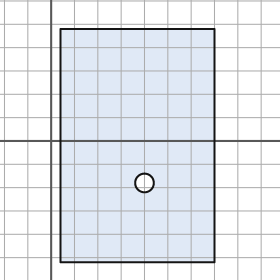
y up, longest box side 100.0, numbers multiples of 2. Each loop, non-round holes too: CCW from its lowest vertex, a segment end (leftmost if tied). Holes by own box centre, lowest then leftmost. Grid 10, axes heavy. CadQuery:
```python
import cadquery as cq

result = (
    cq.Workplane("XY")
    .moveTo(4.0, -52.0)
    .lineTo(70.0, -52.0)
    .lineTo(70.0, 48.0)
    .lineTo(4.0, 48.0)
    .close()
    .moveTo(40.0, -18.0)
    .circle(4.0)
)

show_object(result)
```